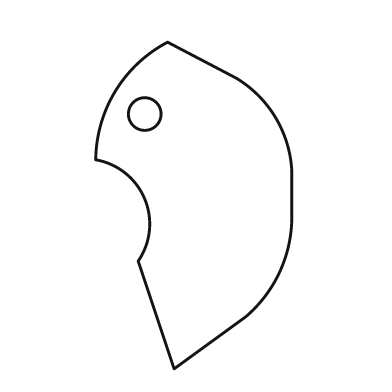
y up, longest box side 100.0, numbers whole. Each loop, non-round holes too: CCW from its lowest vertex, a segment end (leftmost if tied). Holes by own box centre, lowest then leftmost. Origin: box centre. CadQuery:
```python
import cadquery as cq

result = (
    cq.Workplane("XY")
    .moveTo(-6.0, -50.0)
    .lineTo(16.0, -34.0)
    .threePointArc((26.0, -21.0), (30.0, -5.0))
    .lineTo(30.0, 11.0)
    .threePointArc((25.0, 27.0), (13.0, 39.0))
    .lineTo(-8.0, 50.0)
    .threePointArc((-24.0, 35.0), (-30.0, 14.0))
    .threePointArc((-15.0, 2.0), (-17.0, -17.0))
    .close()
    .moveTo(-15.0, 28.0)
    .circle(5.0)
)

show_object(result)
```